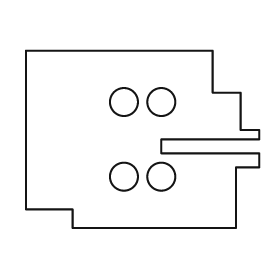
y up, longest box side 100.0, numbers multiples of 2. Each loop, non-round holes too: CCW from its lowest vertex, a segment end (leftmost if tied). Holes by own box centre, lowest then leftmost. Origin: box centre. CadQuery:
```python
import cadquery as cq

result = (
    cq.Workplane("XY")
    .moveTo(-30.0, -38.0)
    .lineTo(40.0, -38.0)
    .lineTo(40.0, -12.0)
    .lineTo(50.0, -12.0)
    .lineTo(50.0, -6.0)
    .lineTo(8.0, -6.0)
    .lineTo(8.0, 0.0)
    .lineTo(50.0, 0.0)
    .lineTo(50.0, 4.0)
    .lineTo(42.0, 4.0)
    .lineTo(42.0, 20.0)
    .lineTo(30.0, 20.0)
    .lineTo(30.0, 38.0)
    .lineTo(-50.0, 38.0)
    .lineTo(-50.0, -30.0)
    .lineTo(-30.0, -30.0)
    .close()
    .moveTo(-8.0, -16.0)
    .circle(6.0)
    .moveTo(8.0, -16.0)
    .circle(6.0)
    .moveTo(-8.0, 16.0)
    .circle(6.0)
    .moveTo(8.0, 16.0)
    .circle(6.0)
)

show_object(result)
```